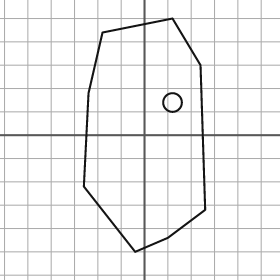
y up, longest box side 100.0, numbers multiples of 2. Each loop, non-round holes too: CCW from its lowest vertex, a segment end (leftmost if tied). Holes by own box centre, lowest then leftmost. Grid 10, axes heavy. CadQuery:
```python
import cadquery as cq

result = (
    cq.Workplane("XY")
    .moveTo(-4.0, -50.0)
    .lineTo(10.0, -44.0)
    .lineTo(26.0, -32.0)
    .lineTo(24.0, 30.0)
    .lineTo(12.0, 50.0)
    .lineTo(-18.0, 44.0)
    .lineTo(-24.0, 18.0)
    .lineTo(-26.0, -22.0)
    .close()
    .moveTo(12.0, 14.0)
    .circle(4.0)
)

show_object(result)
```